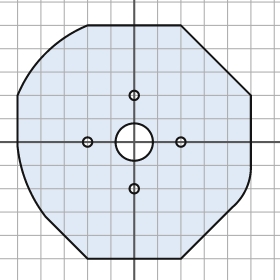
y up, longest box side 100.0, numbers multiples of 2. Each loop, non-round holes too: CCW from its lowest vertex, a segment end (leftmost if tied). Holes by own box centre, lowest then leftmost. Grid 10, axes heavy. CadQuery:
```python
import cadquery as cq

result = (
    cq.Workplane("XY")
    .moveTo(-20.0, -50.0)
    .lineTo(20.0, -50.0)
    .lineTo(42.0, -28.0)
    .threePointArc((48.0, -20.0), (50.0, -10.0))
    .lineTo(50.0, 20.0)
    .lineTo(20.0, 50.0)
    .lineTo(-20.0, 50.0)
    .threePointArc((-38.0, 38.0), (-50.0, 20.0))
    .lineTo(-50.0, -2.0)
    .threePointArc((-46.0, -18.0), (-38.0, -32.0))
    .close()
    .moveTo(0.0, -20.0)
    .circle(2.0)
    .moveTo(-20.0, 0.0)
    .circle(2.0)
    .moveTo(0.0, 0.0)
    .circle(8.0)
    .moveTo(20.0, 0.0)
    .circle(2.0)
    .moveTo(0.0, 20.0)
    .circle(2.0)
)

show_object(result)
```